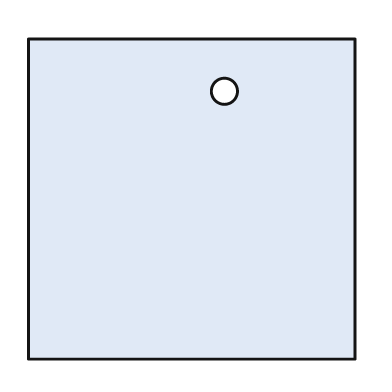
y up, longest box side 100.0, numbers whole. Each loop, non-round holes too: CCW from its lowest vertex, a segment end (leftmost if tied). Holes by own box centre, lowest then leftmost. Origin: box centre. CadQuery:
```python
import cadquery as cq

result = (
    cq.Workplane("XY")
    .moveTo(-50.0, -49.0)
    .lineTo(50.0, -49.0)
    .lineTo(50.0, 49.0)
    .lineTo(-50.0, 49.0)
    .close()
    .moveTo(10.0, 33.0)
    .circle(4.0)
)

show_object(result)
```